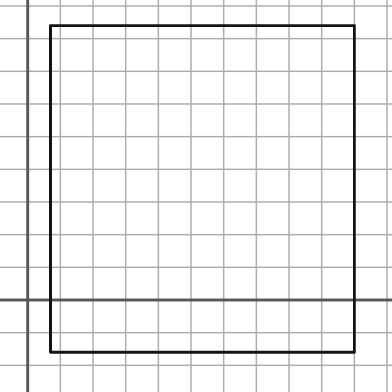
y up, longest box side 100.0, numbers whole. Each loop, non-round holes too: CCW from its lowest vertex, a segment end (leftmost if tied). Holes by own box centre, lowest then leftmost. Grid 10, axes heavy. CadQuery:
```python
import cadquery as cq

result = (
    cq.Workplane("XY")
    .moveTo(7.0, -16.0)
    .lineTo(100.0, -16.0)
    .lineTo(100.0, 84.0)
    .lineTo(7.0, 84.0)
    .close()
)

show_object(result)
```